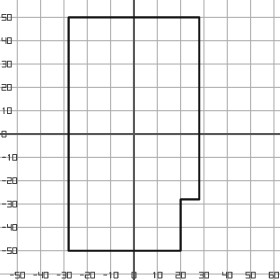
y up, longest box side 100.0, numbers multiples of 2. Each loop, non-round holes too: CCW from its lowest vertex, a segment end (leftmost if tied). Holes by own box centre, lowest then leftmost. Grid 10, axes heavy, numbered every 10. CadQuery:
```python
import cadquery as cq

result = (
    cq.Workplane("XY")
    .moveTo(-28.0, -50.0)
    .lineTo(20.0, -50.0)
    .lineTo(20.0, -28.0)
    .lineTo(28.0, -28.0)
    .lineTo(28.0, 50.0)
    .lineTo(-28.0, 50.0)
    .close()
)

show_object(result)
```